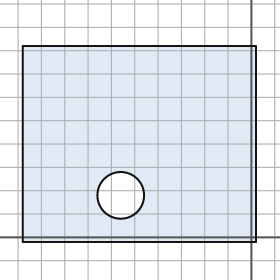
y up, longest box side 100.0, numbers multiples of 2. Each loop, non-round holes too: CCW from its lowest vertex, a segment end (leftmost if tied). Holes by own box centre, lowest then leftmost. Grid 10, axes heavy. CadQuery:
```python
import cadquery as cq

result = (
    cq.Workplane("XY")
    .moveTo(-98.0, -2.0)
    .lineTo(2.0, -2.0)
    .lineTo(2.0, 82.0)
    .lineTo(-98.0, 82.0)
    .close()
    .moveTo(-56.0, 18.0)
    .circle(10.0)
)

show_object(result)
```